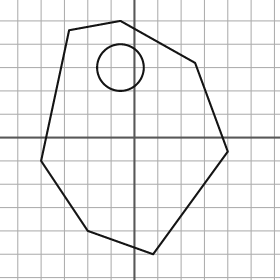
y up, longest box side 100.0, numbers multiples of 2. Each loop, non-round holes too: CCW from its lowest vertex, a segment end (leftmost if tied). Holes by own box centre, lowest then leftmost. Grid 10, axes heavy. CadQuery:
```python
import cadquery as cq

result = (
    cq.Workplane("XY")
    .moveTo(8.0, -50.0)
    .lineTo(40.0, -6.0)
    .lineTo(26.0, 32.0)
    .lineTo(-6.0, 50.0)
    .lineTo(-28.0, 46.0)
    .lineTo(-40.0, -10.0)
    .lineTo(-20.0, -40.0)
    .close()
    .moveTo(-6.0, 30.0)
    .circle(10.0)
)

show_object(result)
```